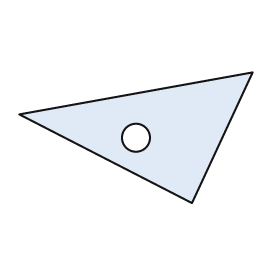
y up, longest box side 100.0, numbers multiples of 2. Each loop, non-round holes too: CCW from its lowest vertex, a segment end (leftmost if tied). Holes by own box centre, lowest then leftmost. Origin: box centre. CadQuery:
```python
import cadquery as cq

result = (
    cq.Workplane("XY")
    .moveTo(24.0, -28.0)
    .lineTo(50.0, 28.0)
    .lineTo(-50.0, 10.0)
    .close()
    .moveTo(0.0, 0.0)
    .circle(6.0)
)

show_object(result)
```